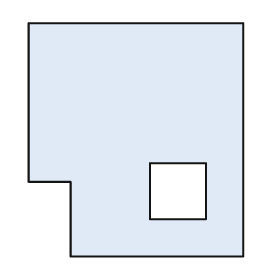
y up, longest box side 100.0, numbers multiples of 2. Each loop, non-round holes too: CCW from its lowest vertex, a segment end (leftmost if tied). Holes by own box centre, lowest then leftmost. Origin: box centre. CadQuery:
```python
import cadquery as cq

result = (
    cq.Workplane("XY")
    .moveTo(-28.0, -50.0)
    .lineTo(46.0, -50.0)
    .lineTo(46.0, 50.0)
    .lineTo(-46.0, 50.0)
    .lineTo(-46.0, -18.0)
    .lineTo(-28.0, -18.0)
    .close()
    .moveTo(6.0, -34.0)
    .lineTo(30.0, -34.0)
    .lineTo(30.0, -10.0)
    .lineTo(6.0, -10.0)
    .close()
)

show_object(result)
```